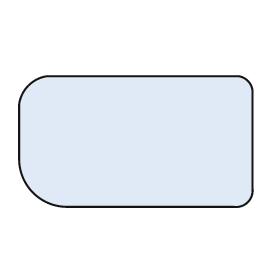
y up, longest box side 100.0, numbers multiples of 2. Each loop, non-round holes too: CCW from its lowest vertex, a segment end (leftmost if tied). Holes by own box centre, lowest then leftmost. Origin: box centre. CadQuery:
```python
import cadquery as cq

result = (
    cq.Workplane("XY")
    .moveTo(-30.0, -28.0)
    .lineTo(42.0, -28.0)
    .threePointArc((48.0, -26.0), (50.0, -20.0))
    .lineTo(50.0, 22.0)
    .threePointArc((48.0, 26.0), (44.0, 28.0))
    .lineTo(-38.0, 28.0)
    .threePointArc((-46.0, 24.0), (-50.0, 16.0))
    .lineTo(-50.0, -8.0)
    .threePointArc((-44.0, -22.0), (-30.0, -28.0))
    .close()
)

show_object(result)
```